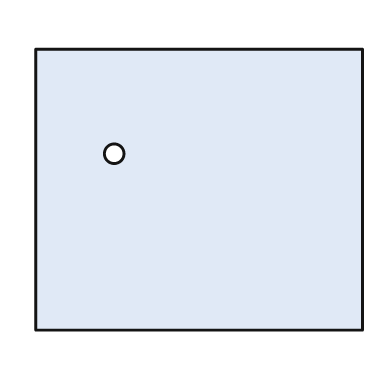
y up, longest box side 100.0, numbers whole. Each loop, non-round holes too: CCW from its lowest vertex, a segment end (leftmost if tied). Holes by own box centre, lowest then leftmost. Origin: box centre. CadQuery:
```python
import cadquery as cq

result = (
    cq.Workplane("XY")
    .moveTo(-50.0, -43.0)
    .lineTo(50.0, -43.0)
    .lineTo(50.0, 43.0)
    .lineTo(-50.0, 43.0)
    .close()
    .moveTo(-26.0, 11.0)
    .circle(3.0)
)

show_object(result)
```